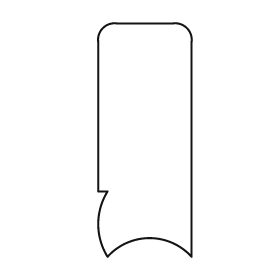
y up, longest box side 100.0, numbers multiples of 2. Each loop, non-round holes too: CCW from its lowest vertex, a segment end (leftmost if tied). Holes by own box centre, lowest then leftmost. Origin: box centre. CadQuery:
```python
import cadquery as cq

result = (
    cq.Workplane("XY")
    .moveTo(-16.0, -50.0)
    .threePointArc((2.0, -42.0), (20.0, -50.0))
    .lineTo(20.0, 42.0)
    .threePointArc((18.0, 48.0), (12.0, 50.0))
    .lineTo(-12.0, 50.0)
    .threePointArc((-18.0, 48.0), (-20.0, 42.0))
    .lineTo(-20.0, -22.0)
    .lineTo(-16.0, -22.0)
    .threePointArc((-20.0, -36.0), (-16.0, -50.0))
    .close()
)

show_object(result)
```